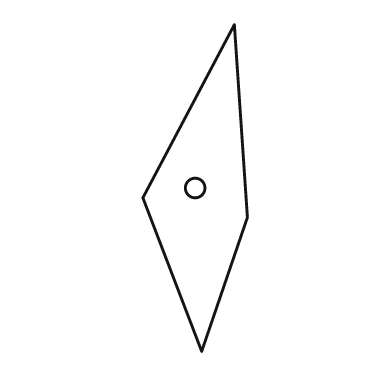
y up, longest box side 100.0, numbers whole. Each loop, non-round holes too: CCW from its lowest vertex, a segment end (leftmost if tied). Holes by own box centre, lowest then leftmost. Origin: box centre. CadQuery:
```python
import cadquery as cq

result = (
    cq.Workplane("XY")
    .moveTo(2.0, -50.0)
    .lineTo(16.0, -9.0)
    .lineTo(12.0, 50.0)
    .lineTo(-16.0, -3.0)
    .close()
    .moveTo(0.0, 0.0)
    .circle(3.0)
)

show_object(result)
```